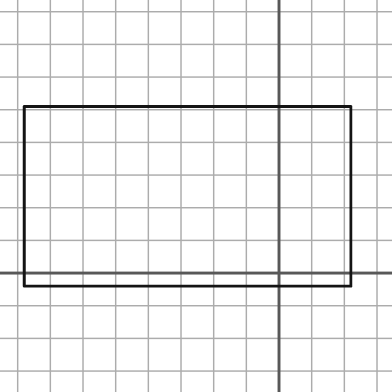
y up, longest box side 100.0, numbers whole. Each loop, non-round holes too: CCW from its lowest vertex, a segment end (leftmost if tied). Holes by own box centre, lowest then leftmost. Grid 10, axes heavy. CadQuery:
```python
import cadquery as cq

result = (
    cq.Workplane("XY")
    .moveTo(-78.0, -4.0)
    .lineTo(22.0, -4.0)
    .lineTo(22.0, 51.0)
    .lineTo(-78.0, 51.0)
    .close()
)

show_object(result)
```